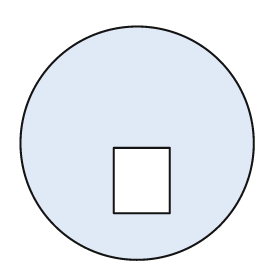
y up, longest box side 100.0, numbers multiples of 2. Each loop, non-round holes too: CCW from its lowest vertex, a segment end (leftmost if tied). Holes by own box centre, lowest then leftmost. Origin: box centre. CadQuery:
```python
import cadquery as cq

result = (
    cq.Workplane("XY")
    .moveTo(0.0, 0.0)
    .circle(50.0)
    .moveTo(-10.0, -30.0)
    .lineTo(14.0, -30.0)
    .lineTo(14.0, -2.0)
    .lineTo(-10.0, -2.0)
    .close()
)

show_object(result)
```